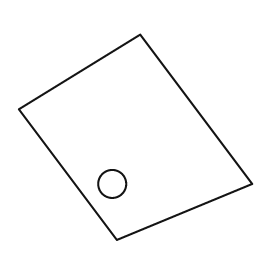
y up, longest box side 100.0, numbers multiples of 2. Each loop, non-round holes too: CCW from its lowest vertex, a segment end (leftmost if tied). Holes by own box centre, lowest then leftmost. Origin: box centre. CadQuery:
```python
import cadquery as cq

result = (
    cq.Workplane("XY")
    .moveTo(-8.0, -44.0)
    .lineTo(50.0, -20.0)
    .lineTo(2.0, 44.0)
    .lineTo(-50.0, 12.0)
    .close()
    .moveTo(-10.0, -20.0)
    .circle(6.0)
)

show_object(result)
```